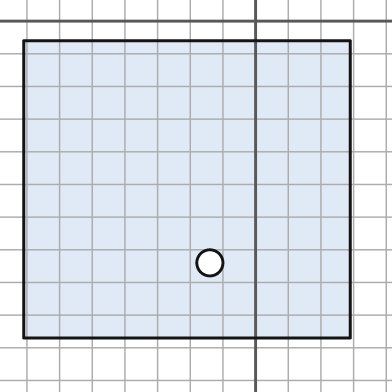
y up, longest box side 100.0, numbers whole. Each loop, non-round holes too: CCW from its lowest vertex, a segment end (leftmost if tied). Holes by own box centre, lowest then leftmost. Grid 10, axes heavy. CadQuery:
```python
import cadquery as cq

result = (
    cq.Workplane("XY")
    .moveTo(-71.0, -97.0)
    .lineTo(29.0, -97.0)
    .lineTo(29.0, -6.0)
    .lineTo(-71.0, -6.0)
    .close()
    .moveTo(-14.0, -74.0)
    .circle(4.0)
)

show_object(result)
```